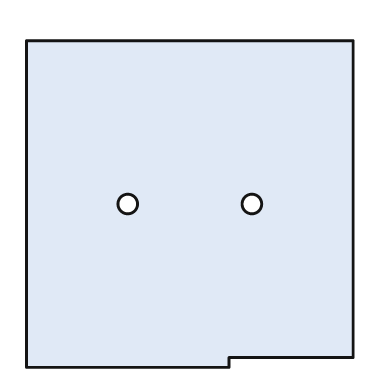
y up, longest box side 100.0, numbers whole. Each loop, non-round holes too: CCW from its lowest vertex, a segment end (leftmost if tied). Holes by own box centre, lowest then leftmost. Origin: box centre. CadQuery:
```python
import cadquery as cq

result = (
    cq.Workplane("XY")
    .moveTo(-50.0, -50.0)
    .lineTo(12.0, -50.0)
    .lineTo(12.0, -47.0)
    .lineTo(50.0, -47.0)
    .lineTo(50.0, 50.0)
    .lineTo(-50.0, 50.0)
    .close()
    .moveTo(-19.0, 0.0)
    .circle(3.0)
    .moveTo(19.0, 0.0)
    .circle(3.0)
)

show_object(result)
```